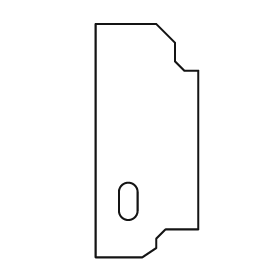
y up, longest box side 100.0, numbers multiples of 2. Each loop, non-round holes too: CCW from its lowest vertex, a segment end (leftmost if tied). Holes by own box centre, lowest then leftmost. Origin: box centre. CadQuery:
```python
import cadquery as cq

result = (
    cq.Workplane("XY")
    .moveTo(-22.0, -50.0)
    .lineTo(-2.0, -50.0)
    .lineTo(4.0, -46.0)
    .lineTo(4.0, -42.0)
    .lineTo(8.0, -38.0)
    .lineTo(22.0, -38.0)
    .lineTo(22.0, 30.0)
    .lineTo(16.0, 30.0)
    .lineTo(12.0, 34.0)
    .lineTo(12.0, 42.0)
    .lineTo(4.0, 50.0)
    .lineTo(-22.0, 50.0)
    .close()
    .moveTo(-12.0, -30.0)
    .threePointArc((-8.0, -34.0), (-4.0, -30.0))
    .lineTo(-4.0, -22.0)
    .threePointArc((-8.0, -18.0), (-12.0, -22.0))
    .close()
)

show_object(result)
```